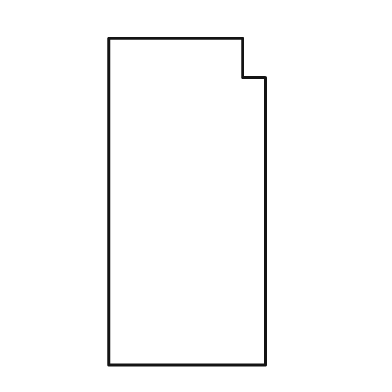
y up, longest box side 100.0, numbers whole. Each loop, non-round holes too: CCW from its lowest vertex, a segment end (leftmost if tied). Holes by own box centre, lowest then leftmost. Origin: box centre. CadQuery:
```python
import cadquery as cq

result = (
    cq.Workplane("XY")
    .moveTo(-24.0, -50.0)
    .lineTo(24.0, -50.0)
    .lineTo(24.0, 38.0)
    .lineTo(17.0, 38.0)
    .lineTo(17.0, 50.0)
    .lineTo(-24.0, 50.0)
    .close()
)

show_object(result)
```